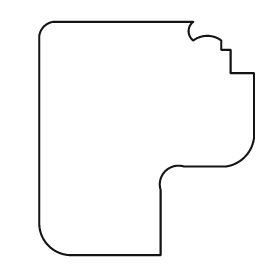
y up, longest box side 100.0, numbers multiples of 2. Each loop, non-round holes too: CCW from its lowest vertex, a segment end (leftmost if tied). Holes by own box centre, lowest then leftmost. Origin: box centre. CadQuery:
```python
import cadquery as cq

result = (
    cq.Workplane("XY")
    .moveTo(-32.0, -50.0)
    .lineTo(6.0, -50.0)
    .lineTo(6.0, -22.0)
    .threePointArc((8.0, -14.0), (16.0, -12.0))
    .lineTo(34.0, -12.0)
    .threePointArc((42.0, -8.0), (46.0, 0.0))
    .lineTo(46.0, 28.0)
    .lineTo(36.0, 28.0)
    .lineTo(36.0, 38.0)
    .lineTo(32.0, 38.0)
    .lineTo(32.0, 42.0)
    .threePointArc((26.0, 44.0), (20.0, 42.0))
    .threePointArc((18.0, 46.0), (20.0, 50.0))
    .lineTo(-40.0, 50.0)
    .threePointArc((-44.0, 48.0), (-46.0, 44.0))
    .lineTo(-46.0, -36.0)
    .threePointArc((-42.0, -46.0), (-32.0, -50.0))
    .close()
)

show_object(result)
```